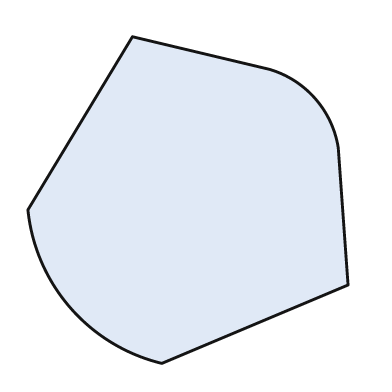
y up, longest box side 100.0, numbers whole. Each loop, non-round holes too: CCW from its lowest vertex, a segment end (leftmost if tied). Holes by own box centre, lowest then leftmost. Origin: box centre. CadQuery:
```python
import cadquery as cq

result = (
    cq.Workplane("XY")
    .moveTo(-8.0, -50.0)
    .lineTo(49.0, -26.0)
    .lineTo(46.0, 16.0)
    .threePointArc((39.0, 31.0), (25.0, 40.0))
    .lineTo(-17.0, 50.0)
    .lineTo(-49.0, -3.0)
    .threePointArc((-36.0, -33.0), (-8.0, -50.0))
    .close()
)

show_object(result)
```